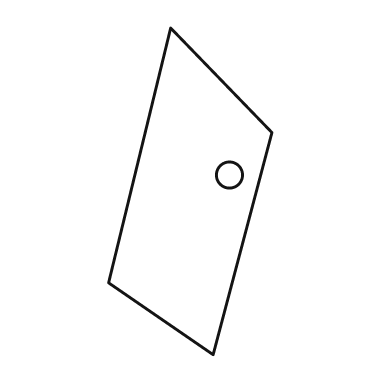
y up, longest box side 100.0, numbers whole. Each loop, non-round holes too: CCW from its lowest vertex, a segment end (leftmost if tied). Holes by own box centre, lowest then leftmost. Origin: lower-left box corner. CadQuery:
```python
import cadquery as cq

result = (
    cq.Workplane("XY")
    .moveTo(32.0, 0.0)
    .lineTo(50.0, 68.0)
    .lineTo(19.0, 100.0)
    .lineTo(0.0, 22.0)
    .close()
    .moveTo(37.0, 55.0)
    .circle(4.0)
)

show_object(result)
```